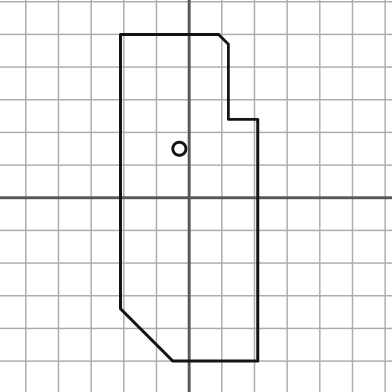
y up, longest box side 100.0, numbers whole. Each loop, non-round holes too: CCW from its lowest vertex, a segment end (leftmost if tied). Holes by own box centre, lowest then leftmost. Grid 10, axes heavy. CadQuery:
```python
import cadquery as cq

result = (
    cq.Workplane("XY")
    .moveTo(-5.0, -50.0)
    .lineTo(21.0, -50.0)
    .lineTo(21.0, 24.0)
    .lineTo(12.0, 24.0)
    .lineTo(12.0, 47.0)
    .lineTo(9.0, 50.0)
    .lineTo(-21.0, 50.0)
    .lineTo(-21.0, -34.0)
    .close()
    .moveTo(-3.0, 15.0)
    .circle(2.0)
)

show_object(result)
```